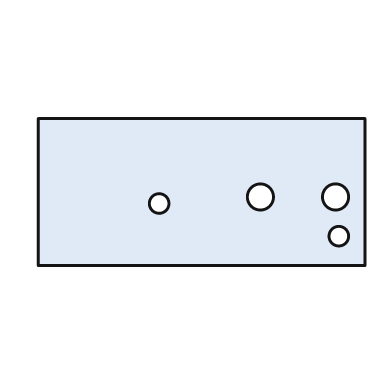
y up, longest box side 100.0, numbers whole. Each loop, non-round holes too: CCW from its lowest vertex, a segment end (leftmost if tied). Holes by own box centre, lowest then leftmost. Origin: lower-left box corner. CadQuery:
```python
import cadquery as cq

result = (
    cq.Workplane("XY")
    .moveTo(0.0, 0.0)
    .lineTo(100.0, 0.0)
    .lineTo(100.0, 45.0)
    .lineTo(0.0, 45.0)
    .close()
    .moveTo(92.0, 9.0)
    .circle(3.0)
    .moveTo(37.0, 19.0)
    .circle(3.0)
    .moveTo(68.0, 21.0)
    .circle(4.0)
    .moveTo(91.0, 21.0)
    .circle(4.0)
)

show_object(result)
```